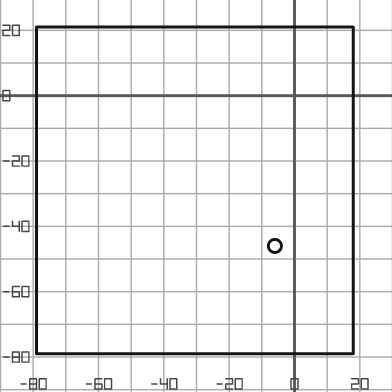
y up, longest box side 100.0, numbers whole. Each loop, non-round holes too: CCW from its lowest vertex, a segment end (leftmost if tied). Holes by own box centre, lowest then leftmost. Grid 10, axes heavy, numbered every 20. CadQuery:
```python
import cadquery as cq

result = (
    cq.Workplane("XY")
    .moveTo(-79.0, -79.0)
    .lineTo(18.0, -79.0)
    .lineTo(18.0, 21.0)
    .lineTo(-79.0, 21.0)
    .close()
    .moveTo(-6.0, -46.0)
    .circle(2.0)
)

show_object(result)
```